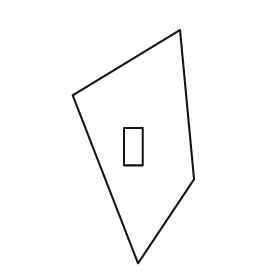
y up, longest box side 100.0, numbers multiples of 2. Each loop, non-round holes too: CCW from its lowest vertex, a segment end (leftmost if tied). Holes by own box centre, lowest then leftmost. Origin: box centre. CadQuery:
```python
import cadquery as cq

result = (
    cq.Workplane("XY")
    .moveTo(2.0, -50.0)
    .lineTo(26.0, -14.0)
    .lineTo(20.0, 50.0)
    .lineTo(-26.0, 22.0)
    .close()
    .moveTo(-4.0, -8.0)
    .lineTo(4.0, -8.0)
    .lineTo(4.0, 8.0)
    .lineTo(-4.0, 8.0)
    .close()
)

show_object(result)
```